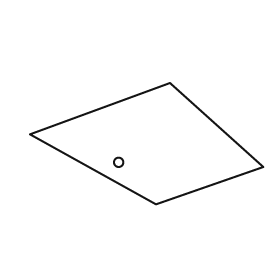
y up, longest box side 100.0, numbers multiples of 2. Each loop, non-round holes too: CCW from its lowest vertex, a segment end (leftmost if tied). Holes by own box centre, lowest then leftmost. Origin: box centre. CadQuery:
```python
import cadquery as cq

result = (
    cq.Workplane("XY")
    .moveTo(4.0, -26.0)
    .lineTo(50.0, -10.0)
    .lineTo(10.0, 26.0)
    .lineTo(-50.0, 4.0)
    .close()
    .moveTo(-12.0, -8.0)
    .circle(2.0)
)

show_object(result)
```